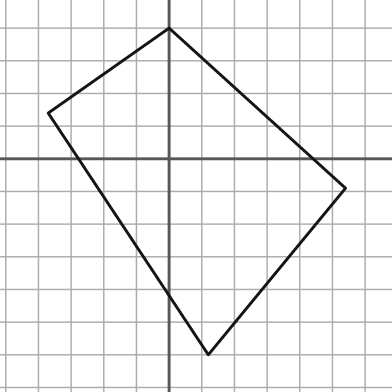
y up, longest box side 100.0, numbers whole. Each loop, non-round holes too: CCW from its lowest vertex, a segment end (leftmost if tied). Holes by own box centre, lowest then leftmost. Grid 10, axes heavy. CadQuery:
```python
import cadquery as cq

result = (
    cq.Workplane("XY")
    .moveTo(12.0, -60.0)
    .lineTo(54.0, -9.0)
    .lineTo(0.0, 40.0)
    .lineTo(-37.0, 14.0)
    .close()
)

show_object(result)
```